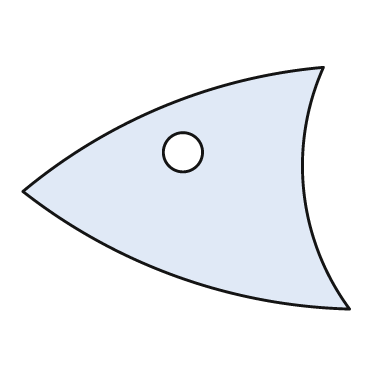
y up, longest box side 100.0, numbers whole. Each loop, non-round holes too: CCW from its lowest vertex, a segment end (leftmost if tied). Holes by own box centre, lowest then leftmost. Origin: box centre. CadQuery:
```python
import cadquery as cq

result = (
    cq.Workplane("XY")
    .moveTo(50.0, -37.0)
    .threePointArc((36.0, -1.0), (42.0, 37.0))
    .threePointArc((-7.0, 25.0), (-50.0, -1.0))
    .threePointArc((-3.0, -27.0), (50.0, -37.0))
    .close()
    .moveTo(-1.0, 11.0)
    .circle(6.0)
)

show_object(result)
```